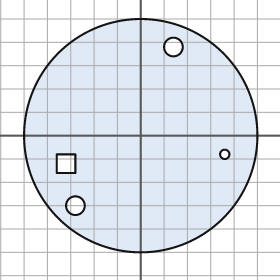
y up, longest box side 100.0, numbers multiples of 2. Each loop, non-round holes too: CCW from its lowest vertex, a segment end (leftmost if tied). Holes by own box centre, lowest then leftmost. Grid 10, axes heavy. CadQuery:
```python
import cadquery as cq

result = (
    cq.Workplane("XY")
    .moveTo(0.0, 0.0)
    .circle(50.0)
    .moveTo(-28.0, -30.0)
    .circle(4.0)
    .moveTo(-36.0, -16.0)
    .lineTo(-28.0, -16.0)
    .lineTo(-28.0, -8.0)
    .lineTo(-36.0, -8.0)
    .close()
    .moveTo(36.0, -8.0)
    .circle(2.0)
    .moveTo(14.0, 38.0)
    .circle(4.0)
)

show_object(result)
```